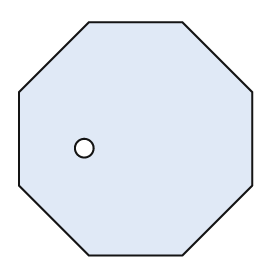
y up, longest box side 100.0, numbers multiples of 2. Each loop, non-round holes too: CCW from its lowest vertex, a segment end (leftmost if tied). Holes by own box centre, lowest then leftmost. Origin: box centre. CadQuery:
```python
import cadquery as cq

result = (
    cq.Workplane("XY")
    .moveTo(-20.0, -50.0)
    .lineTo(20.0, -50.0)
    .lineTo(50.0, -20.0)
    .lineTo(50.0, 20.0)
    .lineTo(20.0, 50.0)
    .lineTo(-20.0, 50.0)
    .lineTo(-50.0, 20.0)
    .lineTo(-50.0, -20.0)
    .close()
    .moveTo(-22.0, -4.0)
    .circle(4.0)
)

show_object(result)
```